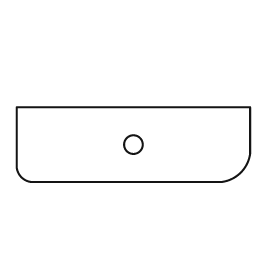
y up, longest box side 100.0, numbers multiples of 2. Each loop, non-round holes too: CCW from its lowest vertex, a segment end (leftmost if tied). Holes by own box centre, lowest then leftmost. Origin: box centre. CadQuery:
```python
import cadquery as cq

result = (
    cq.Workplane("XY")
    .moveTo(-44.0, -16.0)
    .lineTo(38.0, -16.0)
    .threePointArc((46.0, -12.0), (50.0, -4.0))
    .lineTo(50.0, 16.0)
    .lineTo(-50.0, 16.0)
    .lineTo(-50.0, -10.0)
    .threePointArc((-48.0, -14.0), (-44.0, -16.0))
    .close()
    .moveTo(0.0, 0.0)
    .circle(4.0)
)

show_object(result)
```